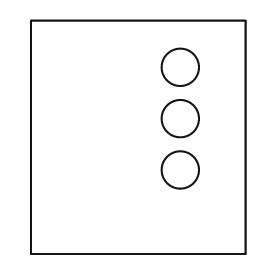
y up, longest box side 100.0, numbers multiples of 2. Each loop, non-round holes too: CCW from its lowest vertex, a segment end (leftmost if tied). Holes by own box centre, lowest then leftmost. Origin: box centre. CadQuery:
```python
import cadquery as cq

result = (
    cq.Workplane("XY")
    .moveTo(-46.0, -50.0)
    .lineTo(46.0, -50.0)
    .lineTo(46.0, 50.0)
    .lineTo(-46.0, 50.0)
    .close()
    .moveTo(18.0, -14.0)
    .circle(8.0)
    .moveTo(18.0, 8.0)
    .circle(8.0)
    .moveTo(18.0, 30.0)
    .circle(8.0)
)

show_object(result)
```